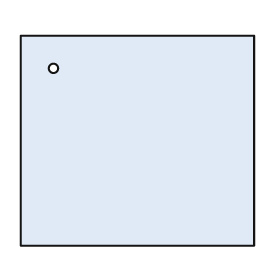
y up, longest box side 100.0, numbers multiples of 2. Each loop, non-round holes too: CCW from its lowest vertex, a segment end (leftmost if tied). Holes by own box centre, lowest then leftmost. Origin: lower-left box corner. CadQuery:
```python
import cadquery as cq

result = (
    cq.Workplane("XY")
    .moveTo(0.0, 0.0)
    .lineTo(100.0, 0.0)
    .lineTo(100.0, 90.0)
    .lineTo(0.0, 90.0)
    .close()
    .moveTo(14.0, 76.0)
    .circle(2.0)
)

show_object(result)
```